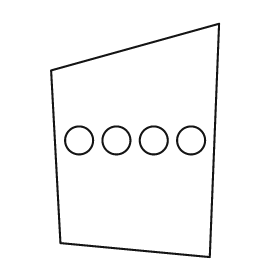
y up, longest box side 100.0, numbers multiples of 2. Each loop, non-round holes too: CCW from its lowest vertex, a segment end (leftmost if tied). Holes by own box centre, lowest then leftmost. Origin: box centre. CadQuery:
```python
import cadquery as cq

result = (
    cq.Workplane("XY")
    .moveTo(32.0, -50.0)
    .lineTo(36.0, 50.0)
    .lineTo(-36.0, 30.0)
    .lineTo(-32.0, -44.0)
    .close()
    .moveTo(-24.0, 0.0)
    .circle(6.0)
    .moveTo(-8.0, 0.0)
    .circle(6.0)
    .moveTo(8.0, 0.0)
    .circle(6.0)
    .moveTo(24.0, 0.0)
    .circle(6.0)
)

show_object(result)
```